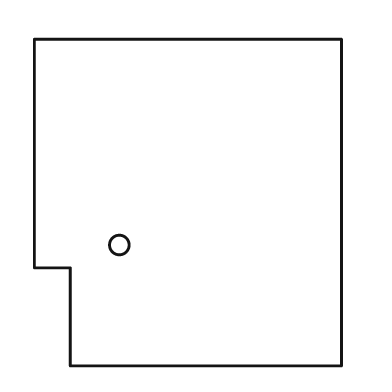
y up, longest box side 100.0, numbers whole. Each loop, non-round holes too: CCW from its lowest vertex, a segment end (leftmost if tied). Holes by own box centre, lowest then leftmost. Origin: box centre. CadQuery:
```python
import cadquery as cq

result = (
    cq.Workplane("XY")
    .moveTo(-36.0, -50.0)
    .lineTo(47.0, -50.0)
    .lineTo(47.0, 50.0)
    .lineTo(-47.0, 50.0)
    .lineTo(-47.0, -20.0)
    .lineTo(-36.0, -20.0)
    .close()
    .moveTo(-21.0, -13.0)
    .circle(3.0)
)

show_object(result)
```